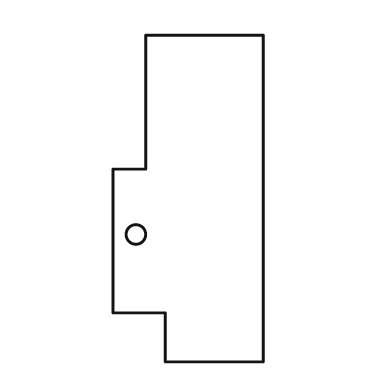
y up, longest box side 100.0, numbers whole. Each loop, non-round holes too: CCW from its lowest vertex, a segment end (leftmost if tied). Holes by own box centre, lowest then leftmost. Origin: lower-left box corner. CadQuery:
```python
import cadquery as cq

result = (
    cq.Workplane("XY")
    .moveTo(16.0, 0.0)
    .lineTo(46.0, 0.0)
    .lineTo(46.0, 100.0)
    .lineTo(10.0, 100.0)
    .lineTo(10.0, 59.0)
    .lineTo(0.0, 59.0)
    .lineTo(0.0, 15.0)
    .lineTo(16.0, 15.0)
    .close()
    .moveTo(7.0, 39.0)
    .circle(3.0)
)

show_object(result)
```